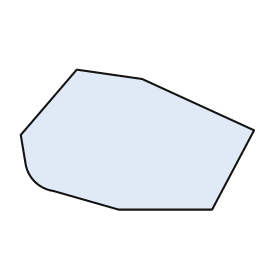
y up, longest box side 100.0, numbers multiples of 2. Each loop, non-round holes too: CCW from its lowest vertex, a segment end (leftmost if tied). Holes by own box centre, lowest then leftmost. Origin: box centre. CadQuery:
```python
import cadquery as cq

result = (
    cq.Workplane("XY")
    .moveTo(-8.0, -30.0)
    .lineTo(32.0, -30.0)
    .lineTo(50.0, 4.0)
    .lineTo(2.0, 26.0)
    .lineTo(-26.0, 30.0)
    .lineTo(-50.0, 2.0)
    .lineTo(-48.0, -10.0)
    .threePointArc((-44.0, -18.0), (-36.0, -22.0))
    .close()
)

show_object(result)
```